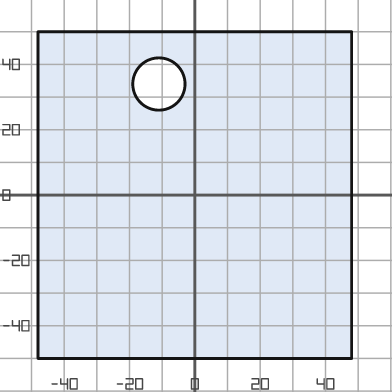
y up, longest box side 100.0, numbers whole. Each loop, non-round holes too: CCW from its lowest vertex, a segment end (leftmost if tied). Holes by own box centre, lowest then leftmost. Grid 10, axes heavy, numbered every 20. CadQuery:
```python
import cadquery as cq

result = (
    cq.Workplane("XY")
    .moveTo(-48.0, -50.0)
    .lineTo(48.0, -50.0)
    .lineTo(48.0, 50.0)
    .lineTo(-48.0, 50.0)
    .close()
    .moveTo(-11.0, 34.0)
    .circle(8.0)
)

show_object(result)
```